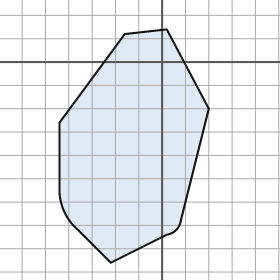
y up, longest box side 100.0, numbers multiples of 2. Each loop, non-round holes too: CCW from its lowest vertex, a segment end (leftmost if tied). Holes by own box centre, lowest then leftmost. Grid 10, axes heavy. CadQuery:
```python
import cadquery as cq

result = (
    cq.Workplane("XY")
    .moveTo(-22.0, -86.0)
    .lineTo(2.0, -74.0)
    .threePointArc((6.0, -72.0), (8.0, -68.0))
    .lineTo(20.0, -20.0)
    .lineTo(2.0, 14.0)
    .lineTo(-16.0, 12.0)
    .lineTo(-44.0, -26.0)
    .lineTo(-44.0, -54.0)
    .threePointArc((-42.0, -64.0), (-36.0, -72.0))
    .close()
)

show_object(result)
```